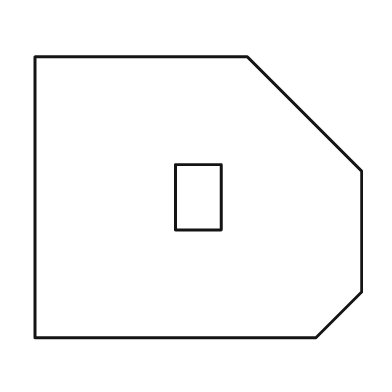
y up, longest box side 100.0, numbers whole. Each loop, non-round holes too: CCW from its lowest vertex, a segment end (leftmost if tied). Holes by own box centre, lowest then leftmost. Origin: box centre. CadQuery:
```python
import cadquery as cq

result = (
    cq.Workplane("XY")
    .moveTo(-50.0, -43.0)
    .lineTo(36.0, -43.0)
    .lineTo(50.0, -29.0)
    .lineTo(50.0, 8.0)
    .lineTo(15.0, 43.0)
    .lineTo(-50.0, 43.0)
    .close()
    .moveTo(-7.0, -10.0)
    .lineTo(7.0, -10.0)
    .lineTo(7.0, 10.0)
    .lineTo(-7.0, 10.0)
    .close()
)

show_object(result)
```